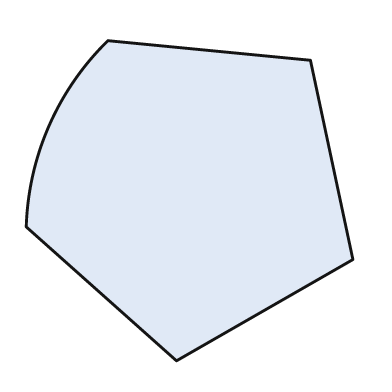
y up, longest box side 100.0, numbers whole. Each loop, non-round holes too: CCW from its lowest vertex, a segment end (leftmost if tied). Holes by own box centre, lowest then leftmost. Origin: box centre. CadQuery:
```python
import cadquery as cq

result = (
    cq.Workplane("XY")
    .moveTo(-4.0, -49.0)
    .lineTo(50.0, -18.0)
    .lineTo(37.0, 43.0)
    .lineTo(-25.0, 49.0)
    .threePointArc((-43.0, 23.0), (-50.0, -8.0))
    .close()
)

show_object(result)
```